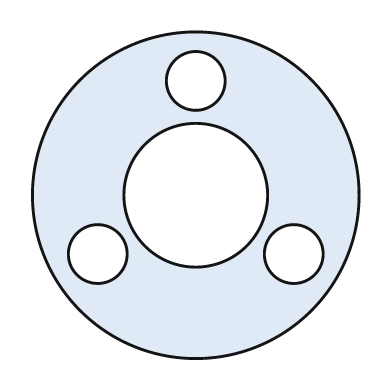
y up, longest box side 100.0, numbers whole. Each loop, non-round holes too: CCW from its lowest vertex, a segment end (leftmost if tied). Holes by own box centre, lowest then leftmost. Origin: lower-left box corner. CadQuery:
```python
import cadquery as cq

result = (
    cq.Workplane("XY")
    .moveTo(50.0, 50.0)
    .circle(50.0)
    .moveTo(20.0, 32.0)
    .circle(9.0)
    .moveTo(80.0, 32.0)
    .circle(9.0)
    .moveTo(50.0, 50.0)
    .circle(22.0)
    .moveTo(50.0, 85.0)
    .circle(9.0)
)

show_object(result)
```